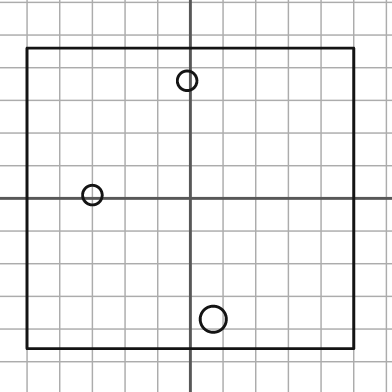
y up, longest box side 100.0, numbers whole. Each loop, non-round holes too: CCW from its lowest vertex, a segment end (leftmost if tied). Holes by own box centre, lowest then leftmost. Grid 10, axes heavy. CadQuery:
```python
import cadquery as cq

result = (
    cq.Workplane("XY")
    .moveTo(-50.0, -46.0)
    .lineTo(50.0, -46.0)
    .lineTo(50.0, 46.0)
    .lineTo(-50.0, 46.0)
    .close()
    .moveTo(7.0, -37.0)
    .circle(4.0)
    .moveTo(-30.0, 1.0)
    .circle(3.0)
    .moveTo(-1.0, 36.0)
    .circle(3.0)
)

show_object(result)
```